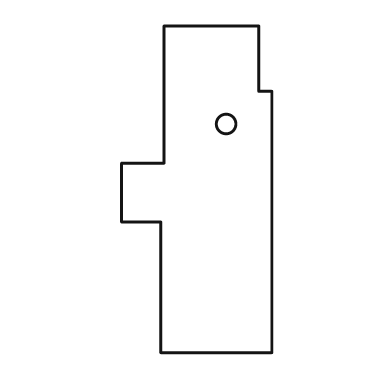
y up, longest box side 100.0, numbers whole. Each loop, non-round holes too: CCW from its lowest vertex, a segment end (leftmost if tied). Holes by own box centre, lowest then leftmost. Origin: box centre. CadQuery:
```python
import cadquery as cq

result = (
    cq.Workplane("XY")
    .moveTo(-11.0, -50.0)
    .lineTo(23.0, -50.0)
    .lineTo(23.0, 30.0)
    .lineTo(19.0, 30.0)
    .lineTo(19.0, 50.0)
    .lineTo(-10.0, 50.0)
    .lineTo(-10.0, 8.0)
    .lineTo(-23.0, 8.0)
    .lineTo(-23.0, -10.0)
    .lineTo(-11.0, -10.0)
    .close()
    .moveTo(9.0, 20.0)
    .circle(3.0)
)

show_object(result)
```